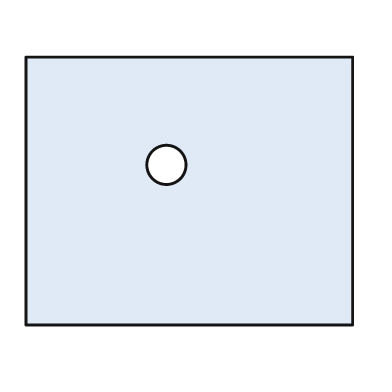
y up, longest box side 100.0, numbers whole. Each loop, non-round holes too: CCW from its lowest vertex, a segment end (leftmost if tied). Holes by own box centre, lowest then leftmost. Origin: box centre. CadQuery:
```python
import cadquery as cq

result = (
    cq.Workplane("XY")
    .moveTo(-50.0, -41.0)
    .lineTo(50.0, -41.0)
    .lineTo(50.0, 41.0)
    .lineTo(-50.0, 41.0)
    .close()
    .moveTo(-7.0, 8.0)
    .circle(6.0)
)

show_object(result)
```